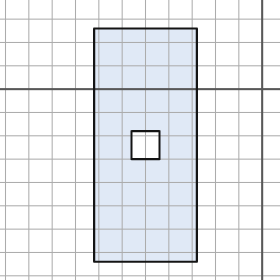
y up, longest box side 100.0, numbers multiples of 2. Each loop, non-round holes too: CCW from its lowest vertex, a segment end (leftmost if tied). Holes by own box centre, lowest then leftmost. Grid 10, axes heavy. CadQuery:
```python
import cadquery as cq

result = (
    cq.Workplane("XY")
    .moveTo(-72.0, -74.0)
    .lineTo(-28.0, -74.0)
    .lineTo(-28.0, 26.0)
    .lineTo(-72.0, 26.0)
    .close()
    .moveTo(-56.0, -30.0)
    .lineTo(-44.0, -30.0)
    .lineTo(-44.0, -18.0)
    .lineTo(-56.0, -18.0)
    .close()
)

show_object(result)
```